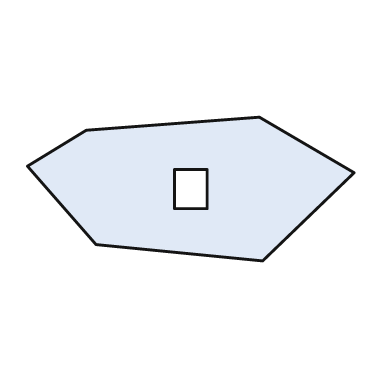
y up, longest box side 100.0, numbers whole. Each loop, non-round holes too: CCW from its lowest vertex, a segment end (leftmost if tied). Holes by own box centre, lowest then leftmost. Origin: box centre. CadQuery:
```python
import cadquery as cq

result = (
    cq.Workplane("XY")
    .moveTo(22.0, -22.0)
    .lineTo(50.0, 5.0)
    .lineTo(21.0, 22.0)
    .lineTo(-32.0, 18.0)
    .lineTo(-50.0, 7.0)
    .lineTo(-29.0, -17.0)
    .close()
    .moveTo(-5.0, -6.0)
    .lineTo(5.0, -6.0)
    .lineTo(5.0, 6.0)
    .lineTo(-5.0, 6.0)
    .close()
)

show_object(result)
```